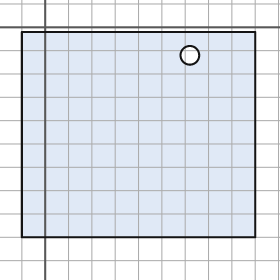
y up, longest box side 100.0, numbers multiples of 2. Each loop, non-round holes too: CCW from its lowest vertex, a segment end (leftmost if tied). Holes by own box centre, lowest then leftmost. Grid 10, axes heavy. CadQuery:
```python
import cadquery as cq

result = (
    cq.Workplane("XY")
    .moveTo(-10.0, -90.0)
    .lineTo(90.0, -90.0)
    .lineTo(90.0, -2.0)
    .lineTo(-10.0, -2.0)
    .close()
    .moveTo(62.0, -12.0)
    .circle(4.0)
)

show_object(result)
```